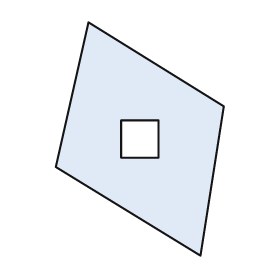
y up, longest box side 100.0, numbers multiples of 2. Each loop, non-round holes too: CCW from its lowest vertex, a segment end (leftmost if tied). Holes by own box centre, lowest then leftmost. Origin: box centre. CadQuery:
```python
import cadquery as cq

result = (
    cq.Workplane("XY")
    .moveTo(26.0, -50.0)
    .lineTo(36.0, 14.0)
    .lineTo(-22.0, 50.0)
    .lineTo(-36.0, -12.0)
    .close()
    .moveTo(-8.0, -8.0)
    .lineTo(8.0, -8.0)
    .lineTo(8.0, 8.0)
    .lineTo(-8.0, 8.0)
    .close()
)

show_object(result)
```